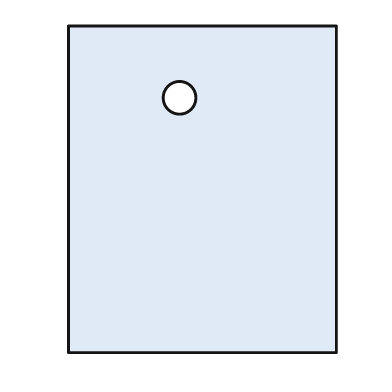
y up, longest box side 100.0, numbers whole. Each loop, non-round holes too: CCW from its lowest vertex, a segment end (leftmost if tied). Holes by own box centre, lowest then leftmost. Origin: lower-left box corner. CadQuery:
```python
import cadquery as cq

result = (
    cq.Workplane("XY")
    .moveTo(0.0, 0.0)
    .lineTo(82.0, 0.0)
    .lineTo(82.0, 100.0)
    .lineTo(0.0, 100.0)
    .close()
    .moveTo(34.0, 78.0)
    .circle(5.0)
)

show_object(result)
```